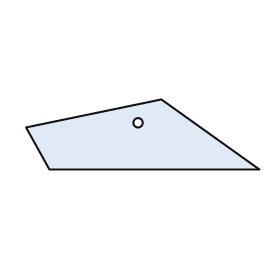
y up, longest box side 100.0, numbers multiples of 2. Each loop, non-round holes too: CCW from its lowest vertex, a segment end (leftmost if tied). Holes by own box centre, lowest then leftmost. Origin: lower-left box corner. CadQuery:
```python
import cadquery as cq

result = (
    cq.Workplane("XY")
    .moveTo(10.0, 0.0)
    .lineTo(100.0, 0.0)
    .lineTo(58.0, 30.0)
    .lineTo(0.0, 18.0)
    .close()
    .moveTo(48.0, 20.0)
    .circle(2.0)
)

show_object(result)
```